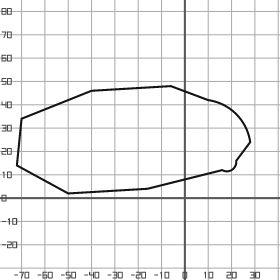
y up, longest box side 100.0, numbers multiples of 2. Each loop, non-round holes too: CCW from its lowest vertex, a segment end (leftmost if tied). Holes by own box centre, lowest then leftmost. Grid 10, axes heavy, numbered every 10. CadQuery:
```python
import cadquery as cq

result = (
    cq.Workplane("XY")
    .moveTo(-50.0, 2.0)
    .lineTo(-16.0, 4.0)
    .lineTo(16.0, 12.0)
    .threePointArc((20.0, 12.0), (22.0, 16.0))
    .lineTo(28.0, 24.0)
    .threePointArc((22.0, 36.0), (10.0, 42.0))
    .lineTo(-6.0, 48.0)
    .lineTo(-40.0, 46.0)
    .lineTo(-70.0, 34.0)
    .lineTo(-72.0, 14.0)
    .close()
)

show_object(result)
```